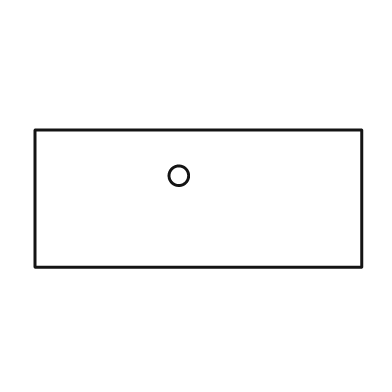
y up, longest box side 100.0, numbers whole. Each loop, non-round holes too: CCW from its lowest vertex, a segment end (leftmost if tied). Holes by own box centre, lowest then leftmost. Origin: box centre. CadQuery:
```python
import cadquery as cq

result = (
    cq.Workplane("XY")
    .moveTo(-50.0, -21.0)
    .lineTo(50.0, -21.0)
    .lineTo(50.0, 21.0)
    .lineTo(-50.0, 21.0)
    .close()
    .moveTo(-6.0, 7.0)
    .circle(3.0)
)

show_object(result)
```